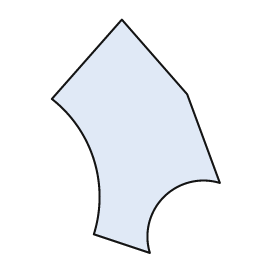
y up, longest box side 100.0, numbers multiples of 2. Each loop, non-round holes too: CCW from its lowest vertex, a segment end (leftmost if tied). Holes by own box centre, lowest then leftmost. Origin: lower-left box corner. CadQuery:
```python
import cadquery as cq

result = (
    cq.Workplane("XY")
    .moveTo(42.0, 0.0)
    .threePointArc((48.0, 24.0), (72.0, 30.0))
    .lineTo(58.0, 68.0)
    .lineTo(30.0, 100.0)
    .lineTo(0.0, 66.0)
    .threePointArc((18.0, 40.0), (18.0, 8.0))
    .close()
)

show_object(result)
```